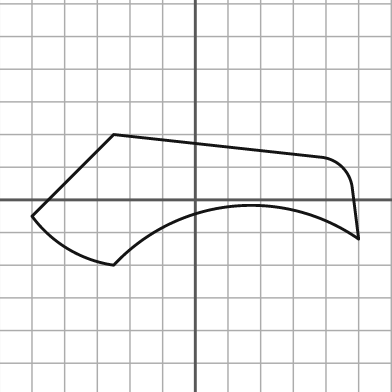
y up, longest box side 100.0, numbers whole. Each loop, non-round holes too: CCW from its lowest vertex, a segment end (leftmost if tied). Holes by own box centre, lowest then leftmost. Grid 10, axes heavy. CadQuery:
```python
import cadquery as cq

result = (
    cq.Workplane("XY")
    .moveTo(-25.0, -20.0)
    .threePointArc((11.0, -2.0), (50.0, -12.0))
    .lineTo(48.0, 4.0)
    .threePointArc((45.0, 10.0), (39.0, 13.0))
    .lineTo(-25.0, 20.0)
    .lineTo(-50.0, -5.0)
    .threePointArc((-39.0, -15.0), (-25.0, -20.0))
    .close()
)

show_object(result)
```